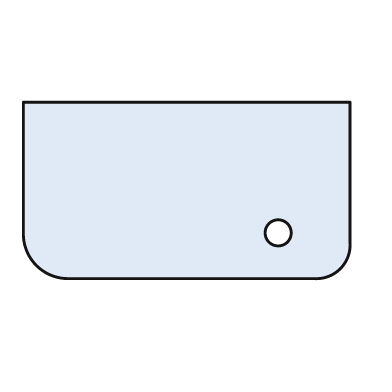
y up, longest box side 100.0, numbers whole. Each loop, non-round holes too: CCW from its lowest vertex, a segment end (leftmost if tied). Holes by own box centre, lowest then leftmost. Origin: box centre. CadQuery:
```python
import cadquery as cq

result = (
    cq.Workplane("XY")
    .moveTo(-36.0, -27.0)
    .lineTo(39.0, -27.0)
    .threePointArc((47.0, -24.0), (50.0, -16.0))
    .lineTo(50.0, 27.0)
    .lineTo(-50.0, 27.0)
    .lineTo(-50.0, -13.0)
    .threePointArc((-46.0, -23.0), (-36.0, -27.0))
    .close()
    .moveTo(28.0, -13.0)
    .circle(4.0)
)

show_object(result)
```